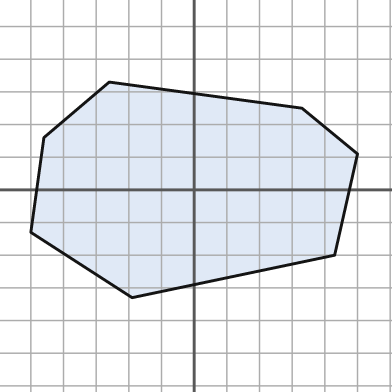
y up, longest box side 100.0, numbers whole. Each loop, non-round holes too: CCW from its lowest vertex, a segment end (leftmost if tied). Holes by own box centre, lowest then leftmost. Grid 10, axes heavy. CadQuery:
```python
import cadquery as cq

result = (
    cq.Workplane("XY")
    .moveTo(-19.0, -33.0)
    .lineTo(43.0, -20.0)
    .lineTo(50.0, 11.0)
    .lineTo(33.0, 25.0)
    .lineTo(-26.0, 33.0)
    .lineTo(-46.0, 16.0)
    .lineTo(-50.0, -13.0)
    .close()
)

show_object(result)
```